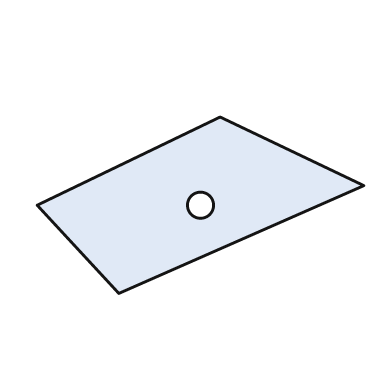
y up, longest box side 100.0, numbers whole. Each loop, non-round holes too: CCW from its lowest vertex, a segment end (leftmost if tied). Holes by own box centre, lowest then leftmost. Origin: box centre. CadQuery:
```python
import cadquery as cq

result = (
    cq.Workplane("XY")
    .moveTo(-25.0, -27.0)
    .lineTo(50.0, 6.0)
    .lineTo(6.0, 27.0)
    .lineTo(-50.0, 0.0)
    .close()
    .moveTo(0.0, 0.0)
    .circle(4.0)
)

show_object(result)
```